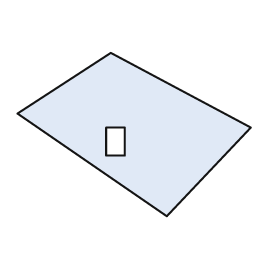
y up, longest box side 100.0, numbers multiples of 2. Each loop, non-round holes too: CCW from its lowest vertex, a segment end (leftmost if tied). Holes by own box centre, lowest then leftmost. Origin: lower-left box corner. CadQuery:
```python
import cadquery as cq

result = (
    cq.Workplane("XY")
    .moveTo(64.0, 0.0)
    .lineTo(100.0, 38.0)
    .lineTo(40.0, 70.0)
    .lineTo(0.0, 44.0)
    .close()
    .moveTo(38.0, 26.0)
    .lineTo(46.0, 26.0)
    .lineTo(46.0, 38.0)
    .lineTo(38.0, 38.0)
    .close()
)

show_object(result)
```